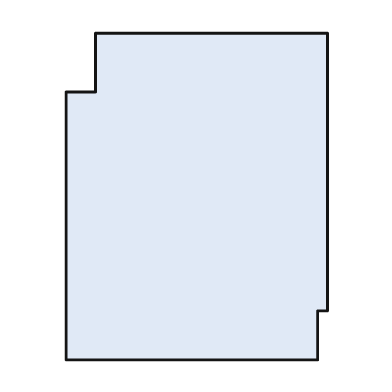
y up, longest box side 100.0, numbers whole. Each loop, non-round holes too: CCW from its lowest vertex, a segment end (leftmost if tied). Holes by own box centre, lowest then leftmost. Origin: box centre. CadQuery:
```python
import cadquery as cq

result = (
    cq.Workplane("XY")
    .moveTo(-40.0, -50.0)
    .lineTo(37.0, -50.0)
    .lineTo(37.0, -35.0)
    .lineTo(40.0, -35.0)
    .lineTo(40.0, 50.0)
    .lineTo(-31.0, 50.0)
    .lineTo(-31.0, 32.0)
    .lineTo(-40.0, 32.0)
    .close()
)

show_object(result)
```